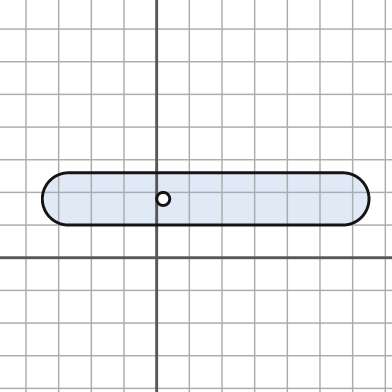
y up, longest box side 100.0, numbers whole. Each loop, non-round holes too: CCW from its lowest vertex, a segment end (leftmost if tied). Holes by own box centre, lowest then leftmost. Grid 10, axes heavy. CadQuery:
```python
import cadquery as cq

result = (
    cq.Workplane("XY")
    .moveTo(-27.0, 10.0)
    .lineTo(57.0, 10.0)
    .threePointArc((65.0, 18.0), (57.0, 26.0))
    .lineTo(-27.0, 26.0)
    .threePointArc((-35.0, 18.0), (-27.0, 10.0))
    .close()
    .moveTo(2.0, 18.0)
    .circle(2.0)
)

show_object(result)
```